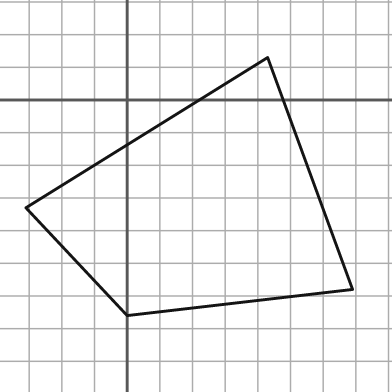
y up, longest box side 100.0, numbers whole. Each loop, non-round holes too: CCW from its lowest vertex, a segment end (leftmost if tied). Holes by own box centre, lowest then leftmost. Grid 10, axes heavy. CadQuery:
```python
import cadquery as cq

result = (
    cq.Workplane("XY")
    .moveTo(0.0, -66.0)
    .lineTo(69.0, -58.0)
    .lineTo(43.0, 13.0)
    .lineTo(-31.0, -33.0)
    .close()
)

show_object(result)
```